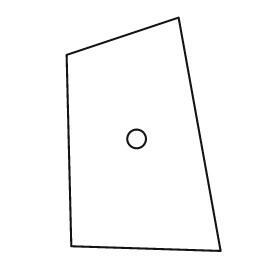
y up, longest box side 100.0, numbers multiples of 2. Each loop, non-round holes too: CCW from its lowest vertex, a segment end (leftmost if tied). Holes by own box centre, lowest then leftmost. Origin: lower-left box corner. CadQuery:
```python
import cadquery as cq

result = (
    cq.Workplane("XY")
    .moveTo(66.0, 0.0)
    .lineTo(48.0, 100.0)
    .lineTo(0.0, 84.0)
    .lineTo(2.0, 2.0)
    .close()
    .moveTo(30.0, 48.0)
    .circle(4.0)
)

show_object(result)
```